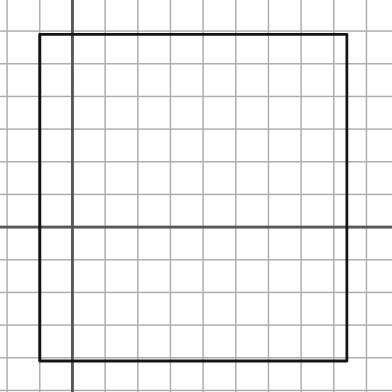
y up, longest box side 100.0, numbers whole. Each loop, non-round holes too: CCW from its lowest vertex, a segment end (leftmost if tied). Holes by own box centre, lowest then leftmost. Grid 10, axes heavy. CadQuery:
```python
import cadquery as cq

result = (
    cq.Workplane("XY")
    .moveTo(-10.0, -41.0)
    .lineTo(84.0, -41.0)
    .lineTo(84.0, 59.0)
    .lineTo(-10.0, 59.0)
    .close()
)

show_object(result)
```